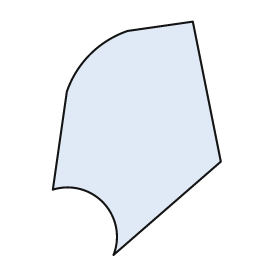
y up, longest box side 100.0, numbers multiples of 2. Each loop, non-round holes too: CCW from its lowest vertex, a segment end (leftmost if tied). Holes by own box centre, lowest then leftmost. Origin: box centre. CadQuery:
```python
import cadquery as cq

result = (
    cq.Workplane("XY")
    .moveTo(-10.0, -50.0)
    .lineTo(36.0, -10.0)
    .lineTo(24.0, 50.0)
    .lineTo(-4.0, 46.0)
    .threePointArc((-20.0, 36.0), (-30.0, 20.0))
    .lineTo(-36.0, -22.0)
    .threePointArc((-14.0, -28.0), (-10.0, -50.0))
    .close()
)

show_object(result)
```